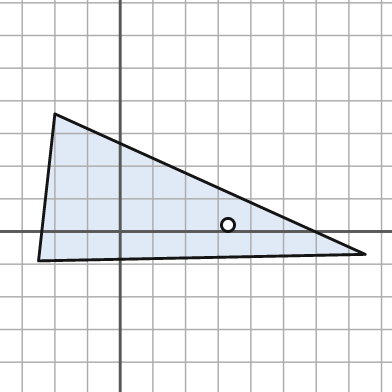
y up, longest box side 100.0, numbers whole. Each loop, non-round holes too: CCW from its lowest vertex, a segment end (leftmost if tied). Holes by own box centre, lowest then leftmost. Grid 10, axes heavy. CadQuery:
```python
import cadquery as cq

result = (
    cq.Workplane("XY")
    .moveTo(-25.0, -9.0)
    .lineTo(75.0, -7.0)
    .lineTo(-20.0, 36.0)
    .close()
    .moveTo(33.0, 2.0)
    .circle(2.0)
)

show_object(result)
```